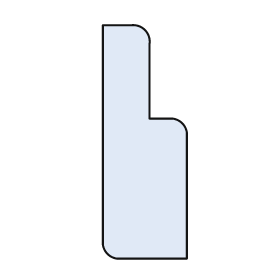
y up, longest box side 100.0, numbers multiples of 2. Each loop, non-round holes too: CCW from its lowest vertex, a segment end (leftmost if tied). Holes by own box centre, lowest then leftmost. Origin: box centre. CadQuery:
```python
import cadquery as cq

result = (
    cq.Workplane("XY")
    .moveTo(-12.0, -50.0)
    .lineTo(18.0, -50.0)
    .lineTo(18.0, 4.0)
    .threePointArc((16.0, 8.0), (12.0, 10.0))
    .lineTo(2.0, 10.0)
    .lineTo(2.0, 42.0)
    .threePointArc((0.0, 48.0), (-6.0, 50.0))
    .lineTo(-18.0, 50.0)
    .lineTo(-18.0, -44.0)
    .threePointArc((-16.0, -48.0), (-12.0, -50.0))
    .close()
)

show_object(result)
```